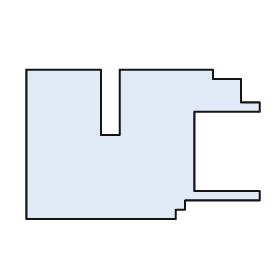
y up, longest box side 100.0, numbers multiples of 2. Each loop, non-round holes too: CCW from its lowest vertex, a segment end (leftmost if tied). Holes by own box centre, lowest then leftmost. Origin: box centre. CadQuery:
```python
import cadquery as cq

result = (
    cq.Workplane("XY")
    .moveTo(-50.0, -32.0)
    .lineTo(14.0, -32.0)
    .lineTo(14.0, -28.0)
    .lineTo(18.0, -28.0)
    .lineTo(18.0, -24.0)
    .lineTo(50.0, -24.0)
    .lineTo(50.0, -20.0)
    .lineTo(22.0, -20.0)
    .lineTo(22.0, 14.0)
    .lineTo(50.0, 14.0)
    .lineTo(50.0, 18.0)
    .lineTo(42.0, 18.0)
    .lineTo(42.0, 28.0)
    .lineTo(30.0, 28.0)
    .lineTo(30.0, 32.0)
    .lineTo(-10.0, 32.0)
    .lineTo(-10.0, 4.0)
    .lineTo(-18.0, 4.0)
    .lineTo(-18.0, 32.0)
    .lineTo(-50.0, 32.0)
    .close()
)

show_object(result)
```